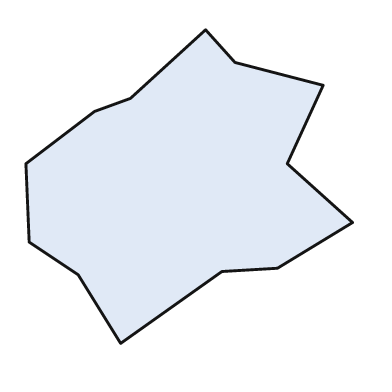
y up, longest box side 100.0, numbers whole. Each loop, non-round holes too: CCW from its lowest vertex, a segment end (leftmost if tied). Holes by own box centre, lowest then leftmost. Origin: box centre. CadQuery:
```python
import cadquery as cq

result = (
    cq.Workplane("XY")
    .moveTo(-21.0, -48.0)
    .lineTo(10.0, -26.0)
    .lineTo(27.0, -25.0)
    .lineTo(50.0, -11.0)
    .lineTo(30.0, 7.0)
    .lineTo(41.0, 31.0)
    .lineTo(14.0, 38.0)
    .lineTo(5.0, 48.0)
    .lineTo(-18.0, 27.0)
    .lineTo(-29.0, 23.0)
    .lineTo(-50.0, 7.0)
    .lineTo(-49.0, -17.0)
    .lineTo(-34.0, -27.0)
    .close()
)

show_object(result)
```